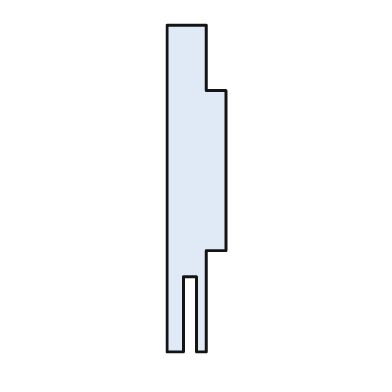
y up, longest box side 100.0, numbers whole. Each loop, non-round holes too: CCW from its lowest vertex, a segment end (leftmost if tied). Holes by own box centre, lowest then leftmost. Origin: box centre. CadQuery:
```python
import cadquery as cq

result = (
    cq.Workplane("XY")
    .moveTo(-9.0, -50.0)
    .lineTo(-4.0, -50.0)
    .lineTo(-4.0, -27.0)
    .lineTo(0.0, -27.0)
    .lineTo(0.0, -50.0)
    .lineTo(3.0, -50.0)
    .lineTo(3.0, -19.0)
    .lineTo(9.0, -19.0)
    .lineTo(9.0, 30.0)
    .lineTo(3.0, 30.0)
    .lineTo(3.0, 50.0)
    .lineTo(-9.0, 50.0)
    .close()
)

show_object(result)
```